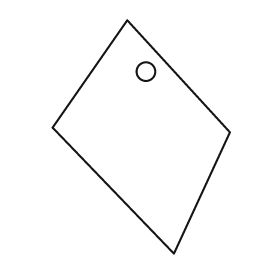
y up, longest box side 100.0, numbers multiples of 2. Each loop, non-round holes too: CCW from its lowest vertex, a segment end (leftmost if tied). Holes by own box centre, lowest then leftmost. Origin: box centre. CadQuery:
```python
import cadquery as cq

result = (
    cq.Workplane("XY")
    .moveTo(14.0, -50.0)
    .lineTo(38.0, 2.0)
    .lineTo(-6.0, 50.0)
    .lineTo(-38.0, 4.0)
    .close()
    .moveTo(2.0, 28.0)
    .circle(4.0)
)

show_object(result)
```